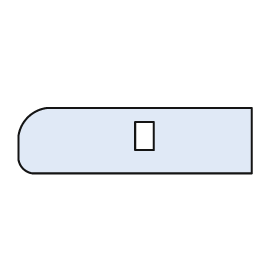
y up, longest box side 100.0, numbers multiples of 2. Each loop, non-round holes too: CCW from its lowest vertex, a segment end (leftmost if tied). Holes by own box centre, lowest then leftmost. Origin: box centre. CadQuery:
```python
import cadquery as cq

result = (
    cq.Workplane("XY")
    .moveTo(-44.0, -14.0)
    .lineTo(50.0, -14.0)
    .lineTo(50.0, 14.0)
    .lineTo(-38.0, 14.0)
    .threePointArc((-46.0, 10.0), (-50.0, 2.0))
    .lineTo(-50.0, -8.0)
    .threePointArc((-48.0, -12.0), (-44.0, -14.0))
    .close()
    .moveTo(0.0, -4.0)
    .lineTo(8.0, -4.0)
    .lineTo(8.0, 8.0)
    .lineTo(0.0, 8.0)
    .close()
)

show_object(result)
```